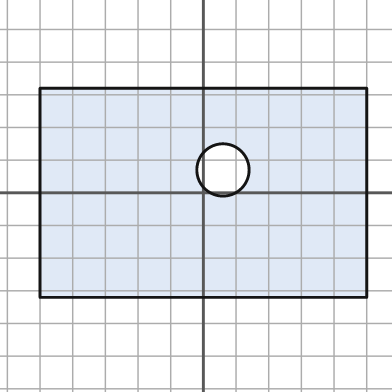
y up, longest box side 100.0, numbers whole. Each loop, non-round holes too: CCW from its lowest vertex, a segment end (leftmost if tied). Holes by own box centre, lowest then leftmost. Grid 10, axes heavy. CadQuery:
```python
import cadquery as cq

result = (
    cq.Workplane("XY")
    .moveTo(-50.0, -32.0)
    .lineTo(50.0, -32.0)
    .lineTo(50.0, 32.0)
    .lineTo(-50.0, 32.0)
    .close()
    .moveTo(6.0, 7.0)
    .circle(8.0)
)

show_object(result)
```